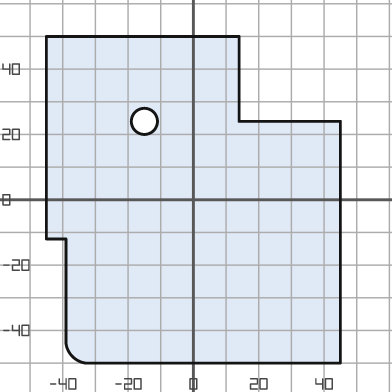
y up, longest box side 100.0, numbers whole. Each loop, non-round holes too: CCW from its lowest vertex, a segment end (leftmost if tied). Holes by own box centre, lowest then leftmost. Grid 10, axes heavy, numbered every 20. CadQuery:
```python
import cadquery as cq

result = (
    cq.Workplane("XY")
    .moveTo(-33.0, -50.0)
    .lineTo(45.0, -50.0)
    .lineTo(45.0, 24.0)
    .lineTo(14.0, 24.0)
    .lineTo(14.0, 50.0)
    .lineTo(-45.0, 50.0)
    .lineTo(-45.0, -12.0)
    .lineTo(-39.0, -12.0)
    .lineTo(-39.0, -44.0)
    .threePointArc((-37.0, -48.0), (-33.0, -50.0))
    .close()
    .moveTo(-15.0, 24.0)
    .circle(4.0)
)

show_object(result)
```